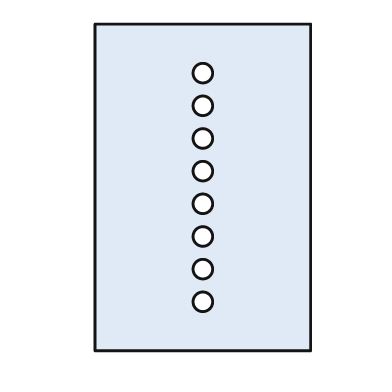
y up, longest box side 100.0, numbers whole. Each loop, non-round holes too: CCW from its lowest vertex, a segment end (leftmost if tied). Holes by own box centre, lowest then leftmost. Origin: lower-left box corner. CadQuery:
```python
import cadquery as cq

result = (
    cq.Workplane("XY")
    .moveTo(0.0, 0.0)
    .lineTo(66.0, 0.0)
    .lineTo(66.0, 100.0)
    .lineTo(0.0, 100.0)
    .close()
    .moveTo(33.0, 15.0)
    .circle(3.0)
    .moveTo(33.0, 25.0)
    .circle(3.0)
    .moveTo(33.0, 35.0)
    .circle(3.0)
    .moveTo(33.0, 45.0)
    .circle(3.0)
    .moveTo(33.0, 55.0)
    .circle(3.0)
    .moveTo(33.0, 65.0)
    .circle(3.0)
    .moveTo(33.0, 75.0)
    .circle(3.0)
    .moveTo(33.0, 85.0)
    .circle(3.0)
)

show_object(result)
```